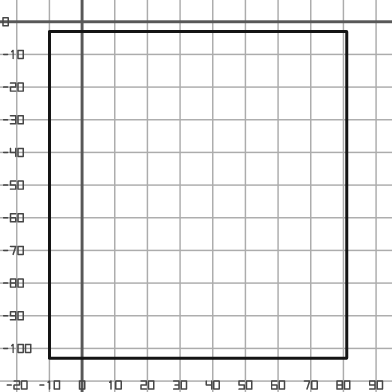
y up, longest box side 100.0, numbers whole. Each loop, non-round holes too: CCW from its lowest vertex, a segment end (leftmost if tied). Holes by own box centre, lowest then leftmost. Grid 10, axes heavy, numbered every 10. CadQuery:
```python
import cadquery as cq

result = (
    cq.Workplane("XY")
    .moveTo(-10.0, -103.0)
    .lineTo(81.0, -103.0)
    .lineTo(81.0, -3.0)
    .lineTo(-10.0, -3.0)
    .close()
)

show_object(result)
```